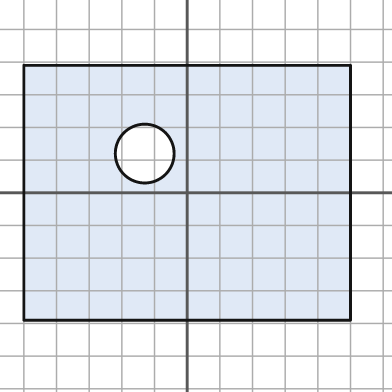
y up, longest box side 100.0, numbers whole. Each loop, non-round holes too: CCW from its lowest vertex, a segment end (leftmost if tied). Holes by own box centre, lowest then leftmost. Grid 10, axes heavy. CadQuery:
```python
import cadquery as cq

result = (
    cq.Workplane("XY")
    .moveTo(-50.0, -39.0)
    .lineTo(50.0, -39.0)
    .lineTo(50.0, 39.0)
    .lineTo(-50.0, 39.0)
    .close()
    .moveTo(-13.0, 12.0)
    .circle(9.0)
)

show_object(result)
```